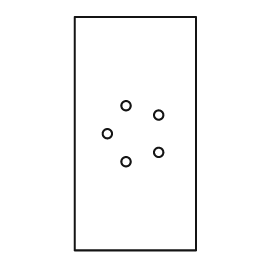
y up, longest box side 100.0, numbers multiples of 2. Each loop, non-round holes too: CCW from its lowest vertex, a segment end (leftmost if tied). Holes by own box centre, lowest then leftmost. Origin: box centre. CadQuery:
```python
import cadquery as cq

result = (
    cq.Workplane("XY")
    .moveTo(-26.0, -50.0)
    .lineTo(26.0, -50.0)
    .lineTo(26.0, 50.0)
    .lineTo(-26.0, 50.0)
    .close()
    .moveTo(-4.0, -12.0)
    .circle(2.0)
    .moveTo(10.0, -8.0)
    .circle(2.0)
    .moveTo(-12.0, 0.0)
    .circle(2.0)
    .moveTo(10.0, 8.0)
    .circle(2.0)
    .moveTo(-4.0, 12.0)
    .circle(2.0)
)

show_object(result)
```